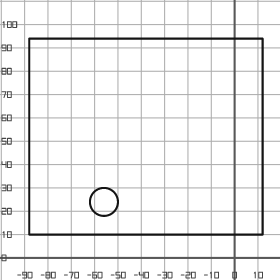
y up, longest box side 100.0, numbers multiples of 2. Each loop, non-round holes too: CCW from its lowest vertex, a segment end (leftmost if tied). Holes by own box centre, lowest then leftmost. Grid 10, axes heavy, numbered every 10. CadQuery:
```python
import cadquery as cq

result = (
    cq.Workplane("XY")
    .moveTo(-88.0, 10.0)
    .lineTo(12.0, 10.0)
    .lineTo(12.0, 94.0)
    .lineTo(-88.0, 94.0)
    .close()
    .moveTo(-56.0, 24.0)
    .circle(6.0)
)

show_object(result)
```